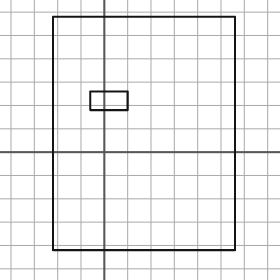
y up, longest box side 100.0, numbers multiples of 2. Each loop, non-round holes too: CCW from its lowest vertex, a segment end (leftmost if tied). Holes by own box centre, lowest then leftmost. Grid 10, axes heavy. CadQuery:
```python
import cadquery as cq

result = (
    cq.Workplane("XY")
    .moveTo(-22.0, -42.0)
    .lineTo(56.0, -42.0)
    .lineTo(56.0, 58.0)
    .lineTo(-22.0, 58.0)
    .close()
    .moveTo(-6.0, 18.0)
    .lineTo(10.0, 18.0)
    .lineTo(10.0, 26.0)
    .lineTo(-6.0, 26.0)
    .close()
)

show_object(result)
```